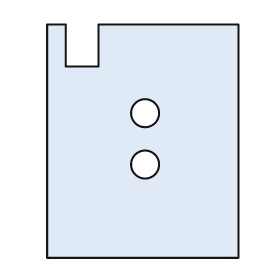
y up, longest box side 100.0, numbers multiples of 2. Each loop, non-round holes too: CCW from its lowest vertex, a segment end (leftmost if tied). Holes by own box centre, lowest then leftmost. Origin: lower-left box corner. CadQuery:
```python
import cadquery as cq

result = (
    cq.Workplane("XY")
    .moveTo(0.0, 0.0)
    .lineTo(82.0, 0.0)
    .lineTo(82.0, 100.0)
    .lineTo(22.0, 100.0)
    .lineTo(22.0, 82.0)
    .lineTo(8.0, 82.0)
    .lineTo(8.0, 100.0)
    .lineTo(0.0, 100.0)
    .close()
    .moveTo(42.0, 40.0)
    .circle(6.0)
    .moveTo(42.0, 62.0)
    .circle(6.0)
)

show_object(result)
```